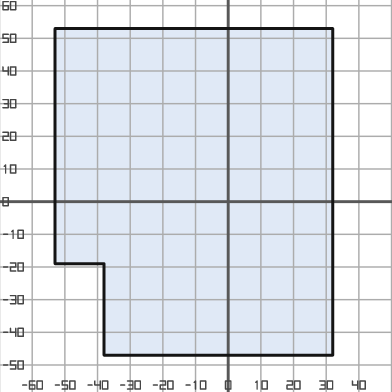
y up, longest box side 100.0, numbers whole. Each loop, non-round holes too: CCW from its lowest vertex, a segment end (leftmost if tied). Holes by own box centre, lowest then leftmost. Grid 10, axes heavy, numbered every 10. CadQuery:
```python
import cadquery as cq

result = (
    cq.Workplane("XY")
    .moveTo(-38.0, -47.0)
    .lineTo(32.0, -47.0)
    .lineTo(32.0, 53.0)
    .lineTo(-53.0, 53.0)
    .lineTo(-53.0, -19.0)
    .lineTo(-38.0, -19.0)
    .close()
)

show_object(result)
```